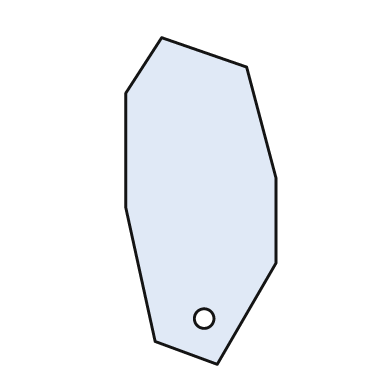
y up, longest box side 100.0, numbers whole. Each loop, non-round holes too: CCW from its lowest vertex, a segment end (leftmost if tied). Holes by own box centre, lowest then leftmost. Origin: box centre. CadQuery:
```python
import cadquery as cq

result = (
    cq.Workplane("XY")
    .moveTo(5.0, -50.0)
    .lineTo(23.0, -19.0)
    .lineTo(23.0, 7.0)
    .lineTo(14.0, 41.0)
    .lineTo(-12.0, 50.0)
    .lineTo(-23.0, 33.0)
    .lineTo(-23.0, -2.0)
    .lineTo(-14.0, -43.0)
    .close()
    .moveTo(1.0, -36.0)
    .circle(3.0)
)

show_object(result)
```